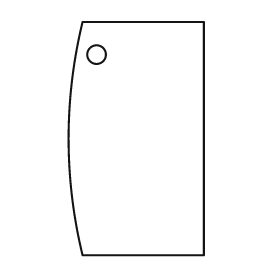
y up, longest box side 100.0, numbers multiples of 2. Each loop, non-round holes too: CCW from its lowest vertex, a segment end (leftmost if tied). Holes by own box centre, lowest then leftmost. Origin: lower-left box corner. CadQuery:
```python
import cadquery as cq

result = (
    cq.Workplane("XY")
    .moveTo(6.0, 0.0)
    .lineTo(58.0, 0.0)
    .lineTo(58.0, 100.0)
    .lineTo(6.0, 100.0)
    .threePointArc((0.0, 50.0), (6.0, 0.0))
    .close()
    .moveTo(12.0, 86.0)
    .circle(4.0)
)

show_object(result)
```